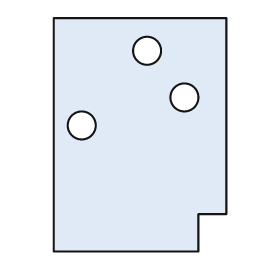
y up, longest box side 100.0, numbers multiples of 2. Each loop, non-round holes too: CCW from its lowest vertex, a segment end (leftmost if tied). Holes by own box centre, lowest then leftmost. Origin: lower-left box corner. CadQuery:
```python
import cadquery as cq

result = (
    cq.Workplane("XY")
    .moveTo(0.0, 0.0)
    .lineTo(62.0, 0.0)
    .lineTo(62.0, 16.0)
    .lineTo(74.0, 16.0)
    .lineTo(74.0, 100.0)
    .lineTo(0.0, 100.0)
    .close()
    .moveTo(12.0, 54.0)
    .circle(6.0)
    .moveTo(56.0, 66.0)
    .circle(6.0)
    .moveTo(40.0, 86.0)
    .circle(6.0)
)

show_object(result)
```